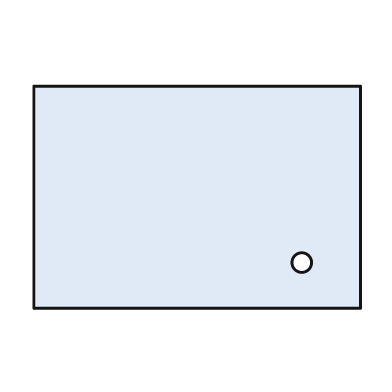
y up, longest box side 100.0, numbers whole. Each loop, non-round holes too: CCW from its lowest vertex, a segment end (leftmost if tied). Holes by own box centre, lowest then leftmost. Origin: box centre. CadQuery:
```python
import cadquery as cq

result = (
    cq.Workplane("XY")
    .moveTo(-50.0, -34.0)
    .lineTo(50.0, -34.0)
    .lineTo(50.0, 34.0)
    .lineTo(-50.0, 34.0)
    .close()
    .moveTo(32.0, -20.0)
    .circle(3.0)
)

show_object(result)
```